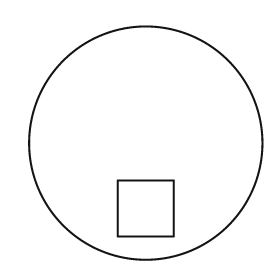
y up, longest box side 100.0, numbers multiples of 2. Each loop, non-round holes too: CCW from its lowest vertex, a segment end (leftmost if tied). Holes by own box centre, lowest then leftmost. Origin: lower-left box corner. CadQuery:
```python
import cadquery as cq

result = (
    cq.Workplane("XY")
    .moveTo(50.0, 50.0)
    .circle(50.0)
    .moveTo(38.0, 10.0)
    .lineTo(62.0, 10.0)
    .lineTo(62.0, 34.0)
    .lineTo(38.0, 34.0)
    .close()
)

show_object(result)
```